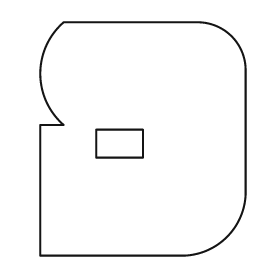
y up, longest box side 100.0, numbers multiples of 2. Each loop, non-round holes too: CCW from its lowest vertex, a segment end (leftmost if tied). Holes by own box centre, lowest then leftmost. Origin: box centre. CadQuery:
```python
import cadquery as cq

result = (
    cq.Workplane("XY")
    .moveTo(-44.0, -50.0)
    .lineTo(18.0, -50.0)
    .threePointArc((36.0, -42.0), (44.0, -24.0))
    .lineTo(44.0, 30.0)
    .threePointArc((38.0, 44.0), (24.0, 50.0))
    .lineTo(-34.0, 50.0)
    .threePointArc((-44.0, 28.0), (-34.0, 6.0))
    .lineTo(-44.0, 6.0)
    .close()
    .moveTo(-20.0, -8.0)
    .lineTo(0.0, -8.0)
    .lineTo(0.0, 4.0)
    .lineTo(-20.0, 4.0)
    .close()
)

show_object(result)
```